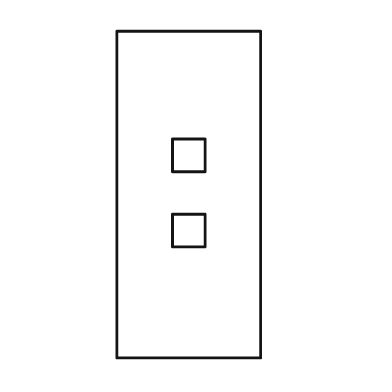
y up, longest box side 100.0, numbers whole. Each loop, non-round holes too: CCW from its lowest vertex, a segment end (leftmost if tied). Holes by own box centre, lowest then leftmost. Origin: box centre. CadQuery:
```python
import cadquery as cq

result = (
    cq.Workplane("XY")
    .moveTo(-22.0, -50.0)
    .lineTo(22.0, -50.0)
    .lineTo(22.0, 50.0)
    .lineTo(-22.0, 50.0)
    .close()
    .moveTo(-5.0, -16.0)
    .lineTo(5.0, -16.0)
    .lineTo(5.0, -6.0)
    .lineTo(-5.0, -6.0)
    .close()
    .moveTo(-5.0, 7.0)
    .lineTo(5.0, 7.0)
    .lineTo(5.0, 17.0)
    .lineTo(-5.0, 17.0)
    .close()
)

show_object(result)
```